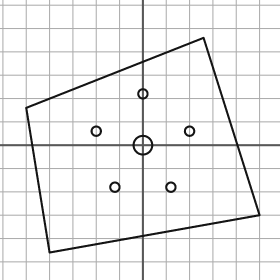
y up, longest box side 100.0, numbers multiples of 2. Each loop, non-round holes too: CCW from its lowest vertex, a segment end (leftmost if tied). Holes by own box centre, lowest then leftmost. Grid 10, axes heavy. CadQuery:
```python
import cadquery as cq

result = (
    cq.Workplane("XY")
    .moveTo(-40.0, -46.0)
    .lineTo(50.0, -30.0)
    .lineTo(26.0, 46.0)
    .lineTo(-50.0, 16.0)
    .close()
    .moveTo(-12.0, -18.0)
    .circle(2.0)
    .moveTo(12.0, -18.0)
    .circle(2.0)
    .moveTo(0.0, 0.0)
    .circle(4.0)
    .moveTo(-20.0, 6.0)
    .circle(2.0)
    .moveTo(20.0, 6.0)
    .circle(2.0)
    .moveTo(0.0, 22.0)
    .circle(2.0)
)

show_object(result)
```